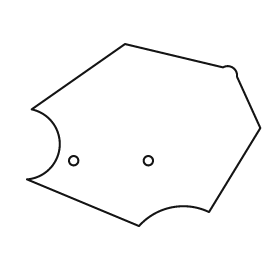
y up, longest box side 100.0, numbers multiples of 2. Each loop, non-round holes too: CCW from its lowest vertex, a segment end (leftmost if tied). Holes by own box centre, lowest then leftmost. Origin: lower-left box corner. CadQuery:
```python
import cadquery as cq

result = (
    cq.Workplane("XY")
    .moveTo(48.0, 0.0)
    .threePointArc((62.0, 8.0), (78.0, 6.0))
    .lineTo(100.0, 42.0)
    .lineTo(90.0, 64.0)
    .threePointArc((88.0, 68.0), (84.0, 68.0))
    .lineTo(42.0, 78.0)
    .lineTo(2.0, 50.0)
    .threePointArc((14.0, 34.0), (0.0, 20.0))
    .close()
    .moveTo(20.0, 28.0)
    .circle(2.0)
    .moveTo(52.0, 28.0)
    .circle(2.0)
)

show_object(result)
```